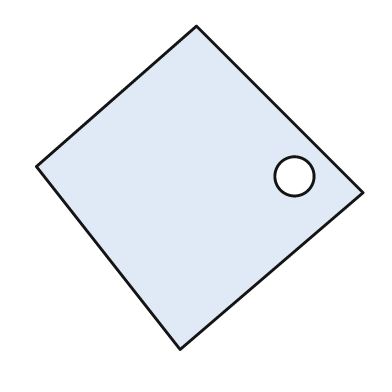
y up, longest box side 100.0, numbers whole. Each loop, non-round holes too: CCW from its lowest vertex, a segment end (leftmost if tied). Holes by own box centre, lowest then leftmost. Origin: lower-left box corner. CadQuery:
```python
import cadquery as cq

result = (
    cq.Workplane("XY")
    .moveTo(44.0, 0.0)
    .lineTo(100.0, 48.0)
    .lineTo(49.0, 99.0)
    .lineTo(0.0, 56.0)
    .close()
    .moveTo(79.0, 53.0)
    .circle(6.0)
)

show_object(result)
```